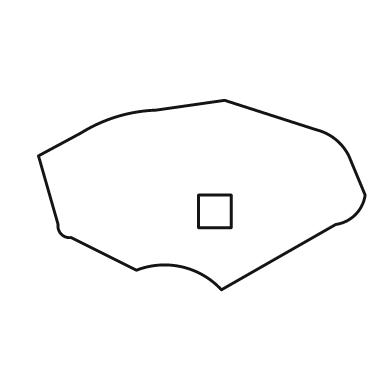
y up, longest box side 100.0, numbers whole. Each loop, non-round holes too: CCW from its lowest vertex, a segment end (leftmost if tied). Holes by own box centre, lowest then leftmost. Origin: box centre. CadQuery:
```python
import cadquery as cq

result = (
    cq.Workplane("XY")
    .moveTo(6.0, -29.0)
    .lineTo(41.0, -9.0)
    .threePointArc((47.0, -6.0), (50.0, 0.0))
    .lineTo(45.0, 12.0)
    .threePointArc((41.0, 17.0), (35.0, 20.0))
    .lineTo(7.0, 29.0)
    .lineTo(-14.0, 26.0)
    .threePointArc((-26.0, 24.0), (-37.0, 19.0))
    .lineTo(-50.0, 12.0)
    .lineTo(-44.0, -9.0)
    .threePointArc((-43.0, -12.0), (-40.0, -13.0))
    .lineTo(-20.0, -23.0)
    .threePointArc((-6.0, -22.0), (6.0, -29.0))
    .close()
    .moveTo(-1.0, -10.0)
    .lineTo(9.0, -10.0)
    .lineTo(9.0, 0.0)
    .lineTo(-1.0, 0.0)
    .close()
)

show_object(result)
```